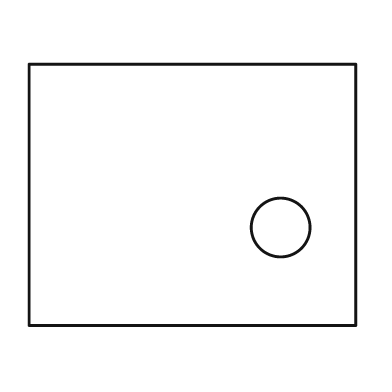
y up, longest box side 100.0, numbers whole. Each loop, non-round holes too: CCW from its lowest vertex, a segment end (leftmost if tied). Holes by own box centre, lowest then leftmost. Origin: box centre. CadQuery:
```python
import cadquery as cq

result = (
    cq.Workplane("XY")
    .moveTo(-50.0, -40.0)
    .lineTo(50.0, -40.0)
    .lineTo(50.0, 40.0)
    .lineTo(-50.0, 40.0)
    .close()
    .moveTo(27.0, -10.0)
    .circle(9.0)
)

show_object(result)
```